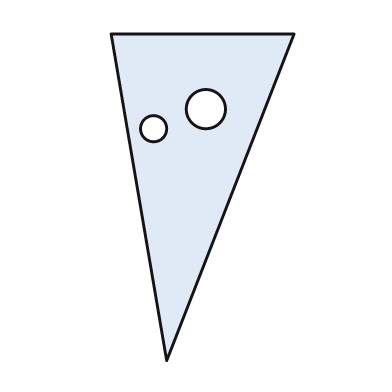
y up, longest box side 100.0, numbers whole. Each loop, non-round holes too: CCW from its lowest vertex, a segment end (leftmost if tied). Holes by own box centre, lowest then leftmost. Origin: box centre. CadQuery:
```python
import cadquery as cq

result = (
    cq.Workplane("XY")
    .moveTo(-11.0, -50.0)
    .lineTo(28.0, 50.0)
    .lineTo(-28.0, 50.0)
    .close()
    .moveTo(-15.0, 21.0)
    .circle(4.0)
    .moveTo(1.0, 27.0)
    .circle(6.0)
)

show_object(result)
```